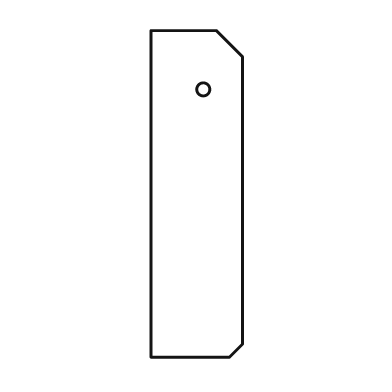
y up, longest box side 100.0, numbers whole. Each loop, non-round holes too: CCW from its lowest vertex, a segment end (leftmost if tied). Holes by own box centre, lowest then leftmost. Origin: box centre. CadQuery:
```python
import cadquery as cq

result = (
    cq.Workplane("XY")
    .moveTo(-14.0, -50.0)
    .lineTo(10.0, -50.0)
    .lineTo(14.0, -46.0)
    .lineTo(14.0, 42.0)
    .lineTo(6.0, 50.0)
    .lineTo(-14.0, 50.0)
    .close()
    .moveTo(2.0, 32.0)
    .circle(2.0)
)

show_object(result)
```